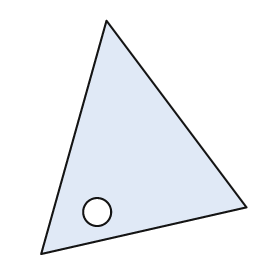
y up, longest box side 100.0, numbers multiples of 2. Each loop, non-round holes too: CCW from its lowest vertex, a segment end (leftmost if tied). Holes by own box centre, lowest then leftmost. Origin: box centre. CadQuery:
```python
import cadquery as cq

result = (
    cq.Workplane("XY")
    .moveTo(-44.0, -50.0)
    .lineTo(44.0, -30.0)
    .lineTo(-16.0, 50.0)
    .close()
    .moveTo(-20.0, -32.0)
    .circle(6.0)
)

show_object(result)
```